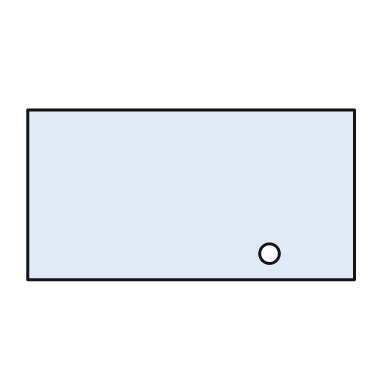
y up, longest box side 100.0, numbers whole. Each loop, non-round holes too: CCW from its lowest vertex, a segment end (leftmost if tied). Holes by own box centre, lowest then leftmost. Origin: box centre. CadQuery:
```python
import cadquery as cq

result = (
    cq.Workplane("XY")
    .moveTo(-50.0, -26.0)
    .lineTo(50.0, -26.0)
    .lineTo(50.0, 26.0)
    .lineTo(-50.0, 26.0)
    .close()
    .moveTo(24.0, -18.0)
    .circle(3.0)
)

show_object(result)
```